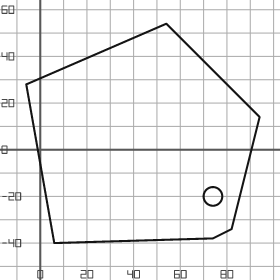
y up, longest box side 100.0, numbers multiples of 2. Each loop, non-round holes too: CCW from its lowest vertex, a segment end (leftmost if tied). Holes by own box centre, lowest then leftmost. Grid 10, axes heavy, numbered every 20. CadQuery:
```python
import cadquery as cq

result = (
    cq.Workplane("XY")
    .moveTo(6.0, -40.0)
    .lineTo(74.0, -38.0)
    .lineTo(82.0, -34.0)
    .lineTo(94.0, 14.0)
    .lineTo(54.0, 54.0)
    .lineTo(-6.0, 28.0)
    .close()
    .moveTo(74.0, -20.0)
    .circle(4.0)
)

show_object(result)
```